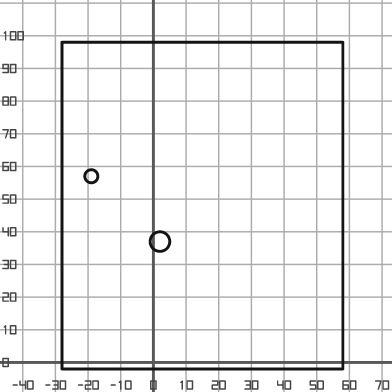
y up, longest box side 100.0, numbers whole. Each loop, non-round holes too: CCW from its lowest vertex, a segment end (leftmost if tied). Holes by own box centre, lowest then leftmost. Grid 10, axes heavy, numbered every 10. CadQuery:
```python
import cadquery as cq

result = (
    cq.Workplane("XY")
    .moveTo(-28.0, -2.0)
    .lineTo(58.0, -2.0)
    .lineTo(58.0, 98.0)
    .lineTo(-28.0, 98.0)
    .close()
    .moveTo(2.0, 37.0)
    .circle(3.0)
    .moveTo(-19.0, 57.0)
    .circle(2.0)
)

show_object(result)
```